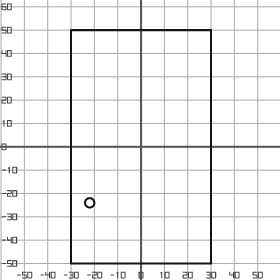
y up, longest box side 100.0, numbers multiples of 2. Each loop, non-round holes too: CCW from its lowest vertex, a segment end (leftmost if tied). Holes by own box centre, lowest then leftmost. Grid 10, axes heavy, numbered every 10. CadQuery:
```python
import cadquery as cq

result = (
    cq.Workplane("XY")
    .moveTo(-30.0, -50.0)
    .lineTo(30.0, -50.0)
    .lineTo(30.0, 50.0)
    .lineTo(-30.0, 50.0)
    .close()
    .moveTo(-22.0, -24.0)
    .circle(2.0)
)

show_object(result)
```